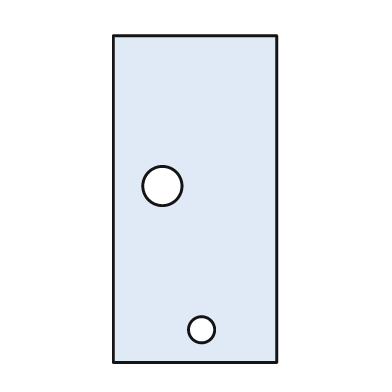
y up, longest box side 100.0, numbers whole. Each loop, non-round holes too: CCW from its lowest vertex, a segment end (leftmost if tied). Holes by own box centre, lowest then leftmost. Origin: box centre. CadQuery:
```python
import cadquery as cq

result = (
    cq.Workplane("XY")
    .moveTo(-25.0, -50.0)
    .lineTo(25.0, -50.0)
    .lineTo(25.0, 50.0)
    .lineTo(-25.0, 50.0)
    .close()
    .moveTo(2.0, -40.0)
    .circle(4.0)
    .moveTo(-10.0, 4.0)
    .circle(6.0)
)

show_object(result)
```